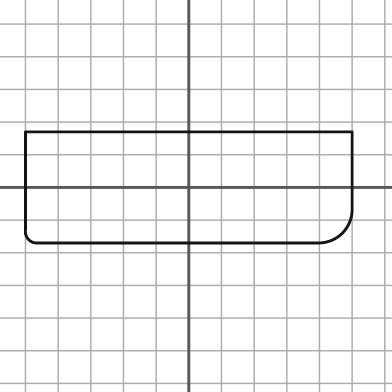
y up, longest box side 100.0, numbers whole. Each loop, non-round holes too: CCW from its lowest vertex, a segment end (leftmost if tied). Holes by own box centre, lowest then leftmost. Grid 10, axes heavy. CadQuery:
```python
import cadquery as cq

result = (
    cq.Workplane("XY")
    .moveTo(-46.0, -17.0)
    .lineTo(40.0, -17.0)
    .threePointArc((47.0, -14.0), (50.0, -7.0))
    .lineTo(50.0, 17.0)
    .lineTo(-50.0, 17.0)
    .lineTo(-50.0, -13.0)
    .threePointArc((-49.0, -16.0), (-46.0, -17.0))
    .close()
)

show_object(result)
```